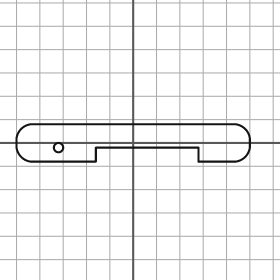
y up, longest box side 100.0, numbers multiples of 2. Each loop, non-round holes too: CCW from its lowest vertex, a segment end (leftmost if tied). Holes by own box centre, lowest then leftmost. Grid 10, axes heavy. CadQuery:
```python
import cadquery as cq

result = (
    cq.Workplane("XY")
    .moveTo(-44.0, -8.0)
    .lineTo(-16.0, -8.0)
    .lineTo(-16.0, -2.0)
    .lineTo(28.0, -2.0)
    .lineTo(28.0, -8.0)
    .lineTo(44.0, -8.0)
    .threePointArc((48.0, -6.0), (50.0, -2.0))
    .lineTo(50.0, 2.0)
    .threePointArc((48.0, 6.0), (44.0, 8.0))
    .lineTo(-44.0, 8.0)
    .threePointArc((-48.0, 6.0), (-50.0, 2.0))
    .lineTo(-50.0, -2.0)
    .threePointArc((-48.0, -6.0), (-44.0, -8.0))
    .close()
    .moveTo(-32.0, -2.0)
    .circle(2.0)
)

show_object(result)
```